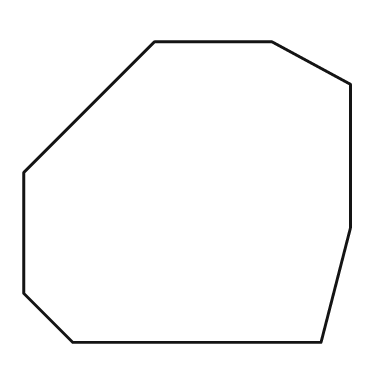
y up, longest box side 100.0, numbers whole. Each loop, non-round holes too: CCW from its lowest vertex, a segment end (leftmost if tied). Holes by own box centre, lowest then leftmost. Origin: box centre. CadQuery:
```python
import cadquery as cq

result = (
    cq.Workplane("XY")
    .moveTo(-35.0, -46.0)
    .lineTo(41.0, -46.0)
    .lineTo(50.0, -11.0)
    .lineTo(50.0, 33.0)
    .lineTo(26.0, 46.0)
    .lineTo(-10.0, 46.0)
    .lineTo(-50.0, 6.0)
    .lineTo(-50.0, -31.0)
    .close()
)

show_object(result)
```